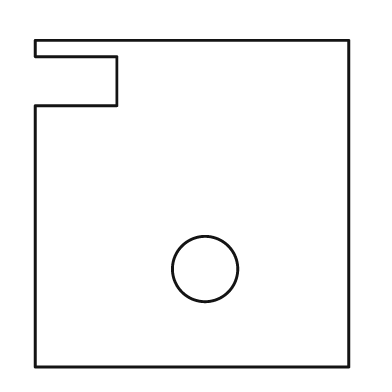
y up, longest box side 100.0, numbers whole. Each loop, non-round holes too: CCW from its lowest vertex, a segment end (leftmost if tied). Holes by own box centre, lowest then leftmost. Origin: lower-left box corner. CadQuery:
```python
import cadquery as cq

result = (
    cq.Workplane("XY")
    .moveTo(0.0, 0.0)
    .lineTo(96.0, 0.0)
    .lineTo(96.0, 100.0)
    .lineTo(0.0, 100.0)
    .lineTo(0.0, 95.0)
    .lineTo(25.0, 95.0)
    .lineTo(25.0, 80.0)
    .lineTo(0.0, 80.0)
    .close()
    .moveTo(52.0, 30.0)
    .circle(10.0)
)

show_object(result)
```